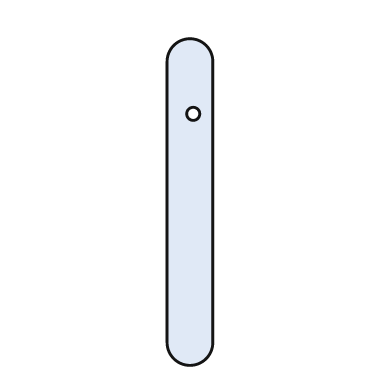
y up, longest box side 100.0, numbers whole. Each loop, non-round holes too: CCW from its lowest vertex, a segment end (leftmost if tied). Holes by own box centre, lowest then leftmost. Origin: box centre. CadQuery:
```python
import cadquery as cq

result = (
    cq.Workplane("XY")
    .moveTo(-7.0, -43.0)
    .threePointArc((0.0, -50.0), (7.0, -43.0))
    .lineTo(7.0, 43.0)
    .threePointArc((0.0, 50.0), (-7.0, 43.0))
    .close()
    .moveTo(1.0, 27.0)
    .circle(2.0)
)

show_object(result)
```